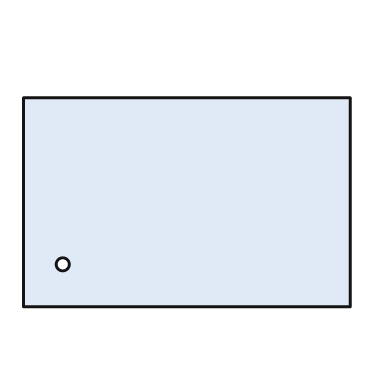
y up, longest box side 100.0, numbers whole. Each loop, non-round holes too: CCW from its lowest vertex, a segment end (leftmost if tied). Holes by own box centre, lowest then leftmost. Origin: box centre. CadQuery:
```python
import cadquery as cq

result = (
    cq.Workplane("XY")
    .moveTo(-50.0, -32.0)
    .lineTo(50.0, -32.0)
    .lineTo(50.0, 32.0)
    .lineTo(-50.0, 32.0)
    .close()
    .moveTo(-38.0, -19.0)
    .circle(2.0)
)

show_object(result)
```